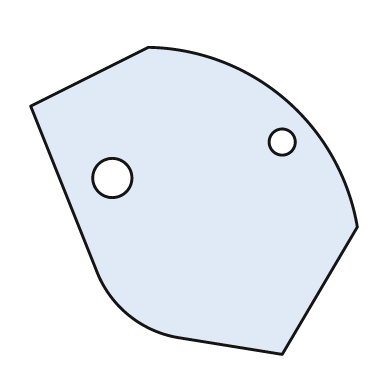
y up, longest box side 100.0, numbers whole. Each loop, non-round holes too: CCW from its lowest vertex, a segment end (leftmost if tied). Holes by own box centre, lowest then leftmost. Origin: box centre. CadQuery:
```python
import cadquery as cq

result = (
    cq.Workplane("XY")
    .moveTo(27.0, -47.0)
    .lineTo(50.0, -8.0)
    .threePointArc((28.0, 31.0), (-14.0, 47.0))
    .lineTo(-50.0, 29.0)
    .lineTo(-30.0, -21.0)
    .threePointArc((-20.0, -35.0), (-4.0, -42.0))
    .close()
    .moveTo(-25.0, 7.0)
    .circle(6.0)
    .moveTo(27.0, 18.0)
    .circle(4.0)
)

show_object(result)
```